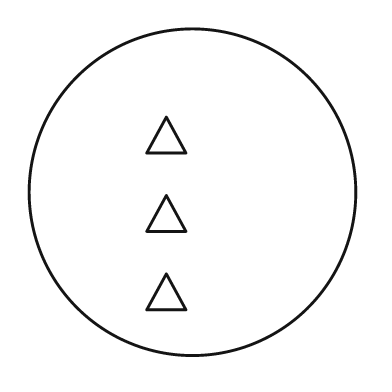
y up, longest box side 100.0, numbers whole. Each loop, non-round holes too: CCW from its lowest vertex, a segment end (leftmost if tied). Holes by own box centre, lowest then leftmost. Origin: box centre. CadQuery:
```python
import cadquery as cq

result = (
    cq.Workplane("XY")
    .moveTo(0.0, 0.0)
    .circle(50.0)
    .moveTo(-14.0, -36.0)
    .lineTo(-2.0, -36.0)
    .lineTo(-8.0, -25.0)
    .close()
    .moveTo(-14.0, -12.0)
    .lineTo(-2.0, -12.0)
    .lineTo(-8.0, -1.0)
    .close()
    .moveTo(-14.0, 12.0)
    .lineTo(-2.0, 12.0)
    .lineTo(-8.0, 23.0)
    .close()
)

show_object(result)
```